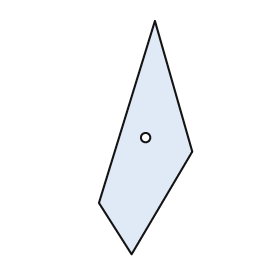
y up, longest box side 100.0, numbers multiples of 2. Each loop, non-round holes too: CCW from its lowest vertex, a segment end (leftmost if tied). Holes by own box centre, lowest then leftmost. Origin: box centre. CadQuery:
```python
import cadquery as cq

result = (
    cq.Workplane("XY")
    .moveTo(-6.0, -50.0)
    .lineTo(20.0, -6.0)
    .lineTo(4.0, 50.0)
    .lineTo(-20.0, -28.0)
    .close()
    .moveTo(0.0, 0.0)
    .circle(2.0)
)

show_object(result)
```